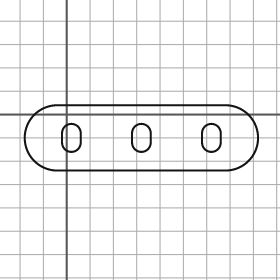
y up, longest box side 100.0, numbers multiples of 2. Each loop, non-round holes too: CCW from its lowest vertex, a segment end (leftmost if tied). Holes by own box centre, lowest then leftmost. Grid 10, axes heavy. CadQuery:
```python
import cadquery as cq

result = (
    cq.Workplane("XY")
    .moveTo(-4.0, -24.0)
    .lineTo(68.0, -24.0)
    .threePointArc((82.0, -10.0), (68.0, 4.0))
    .lineTo(-4.0, 4.0)
    .threePointArc((-18.0, -10.0), (-4.0, -24.0))
    .close()
    .moveTo(-2.0, -12.0)
    .threePointArc((2.0, -16.0), (6.0, -12.0))
    .lineTo(6.0, -8.0)
    .threePointArc((2.0, -4.0), (-2.0, -8.0))
    .close()
    .moveTo(28.0, -12.0)
    .threePointArc((32.0, -16.0), (36.0, -12.0))
    .lineTo(36.0, -8.0)
    .threePointArc((32.0, -4.0), (28.0, -8.0))
    .close()
    .moveTo(58.0, -12.0)
    .threePointArc((62.0, -16.0), (66.0, -12.0))
    .lineTo(66.0, -8.0)
    .threePointArc((62.0, -4.0), (58.0, -8.0))
    .close()
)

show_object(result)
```